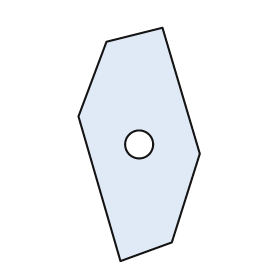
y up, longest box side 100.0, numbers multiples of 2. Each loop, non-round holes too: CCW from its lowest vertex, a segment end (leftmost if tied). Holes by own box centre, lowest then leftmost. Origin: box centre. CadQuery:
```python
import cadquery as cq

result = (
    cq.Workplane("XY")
    .moveTo(-8.0, -50.0)
    .lineTo(14.0, -42.0)
    .lineTo(26.0, -4.0)
    .lineTo(10.0, 50.0)
    .lineTo(-14.0, 44.0)
    .lineTo(-26.0, 12.0)
    .close()
    .moveTo(0.0, 0.0)
    .circle(6.0)
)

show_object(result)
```